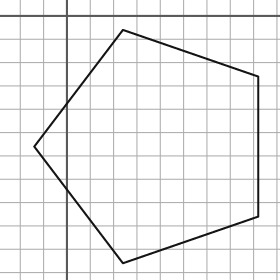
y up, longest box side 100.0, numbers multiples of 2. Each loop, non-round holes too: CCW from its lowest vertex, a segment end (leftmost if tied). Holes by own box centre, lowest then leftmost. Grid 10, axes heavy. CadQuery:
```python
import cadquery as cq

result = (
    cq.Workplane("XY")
    .moveTo(24.0, -106.0)
    .lineTo(82.0, -86.0)
    .lineTo(82.0, -26.0)
    .lineTo(24.0, -6.0)
    .lineTo(-14.0, -56.0)
    .close()
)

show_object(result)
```